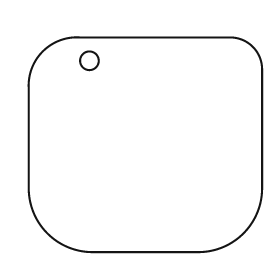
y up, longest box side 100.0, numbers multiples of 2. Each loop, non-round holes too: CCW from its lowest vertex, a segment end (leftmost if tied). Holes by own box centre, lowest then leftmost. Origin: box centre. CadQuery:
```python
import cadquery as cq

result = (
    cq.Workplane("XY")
    .moveTo(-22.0, -46.0)
    .lineTo(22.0, -46.0)
    .threePointArc((42.0, -38.0), (50.0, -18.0))
    .lineTo(50.0, 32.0)
    .threePointArc((46.0, 42.0), (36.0, 46.0))
    .lineTo(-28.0, 46.0)
    .threePointArc((-44.0, 40.0), (-50.0, 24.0))
    .lineTo(-50.0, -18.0)
    .threePointArc((-42.0, -38.0), (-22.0, -46.0))
    .close()
    .moveTo(-24.0, 36.0)
    .circle(4.0)
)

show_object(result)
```